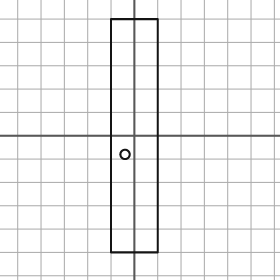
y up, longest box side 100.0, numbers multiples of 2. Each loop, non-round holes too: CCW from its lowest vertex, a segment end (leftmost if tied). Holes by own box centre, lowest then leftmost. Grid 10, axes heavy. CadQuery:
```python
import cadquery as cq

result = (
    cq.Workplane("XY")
    .moveTo(-10.0, -50.0)
    .lineTo(10.0, -50.0)
    .lineTo(10.0, 50.0)
    .lineTo(-10.0, 50.0)
    .close()
    .moveTo(-4.0, -8.0)
    .circle(2.0)
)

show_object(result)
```